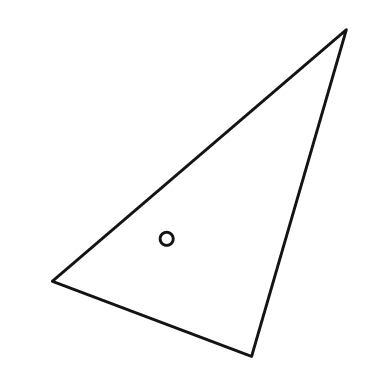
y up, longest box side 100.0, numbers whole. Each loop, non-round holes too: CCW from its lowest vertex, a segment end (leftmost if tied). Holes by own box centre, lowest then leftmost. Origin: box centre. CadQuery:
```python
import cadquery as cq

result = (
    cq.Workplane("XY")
    .moveTo(16.0, -50.0)
    .lineTo(45.0, 50.0)
    .lineTo(-45.0, -27.0)
    .close()
    .moveTo(-10.0, -14.0)
    .circle(2.0)
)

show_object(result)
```